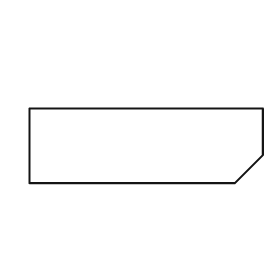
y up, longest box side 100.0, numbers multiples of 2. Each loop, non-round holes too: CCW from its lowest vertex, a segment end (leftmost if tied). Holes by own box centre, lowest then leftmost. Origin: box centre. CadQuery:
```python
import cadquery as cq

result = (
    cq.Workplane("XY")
    .moveTo(-50.0, -16.0)
    .lineTo(38.0, -16.0)
    .lineTo(50.0, -4.0)
    .lineTo(50.0, 16.0)
    .lineTo(-50.0, 16.0)
    .close()
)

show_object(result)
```